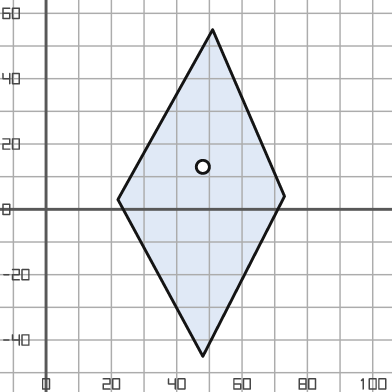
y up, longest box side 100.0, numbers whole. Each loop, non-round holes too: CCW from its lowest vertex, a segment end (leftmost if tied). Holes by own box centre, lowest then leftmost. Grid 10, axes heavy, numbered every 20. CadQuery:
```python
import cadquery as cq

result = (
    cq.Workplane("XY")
    .moveTo(48.0, -45.0)
    .lineTo(73.0, 4.0)
    .lineTo(51.0, 55.0)
    .lineTo(22.0, 3.0)
    .close()
    .moveTo(48.0, 13.0)
    .circle(2.0)
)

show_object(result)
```